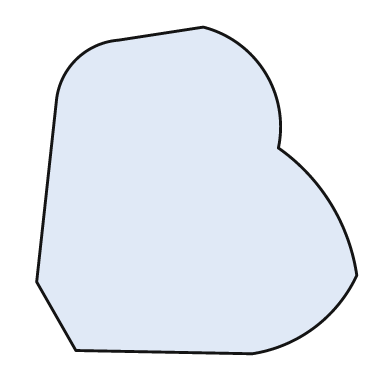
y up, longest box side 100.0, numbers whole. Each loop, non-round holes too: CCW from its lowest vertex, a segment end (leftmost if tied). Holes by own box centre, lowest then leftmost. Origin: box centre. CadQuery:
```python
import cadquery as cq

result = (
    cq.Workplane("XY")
    .moveTo(17.0, -50.0)
    .threePointArc((36.0, -42.0), (49.0, -26.0))
    .threePointArc((41.0, -4.0), (25.0, 13.0))
    .threePointArc((21.0, 36.0), (2.0, 50.0))
    .lineTo(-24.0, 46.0)
    .threePointArc((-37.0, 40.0), (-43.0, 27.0))
    .lineTo(-49.0, -28.0)
    .lineTo(-37.0, -49.0)
    .close()
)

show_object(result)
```